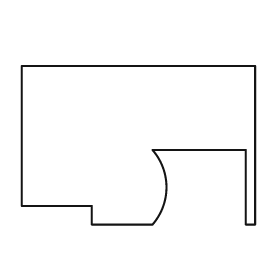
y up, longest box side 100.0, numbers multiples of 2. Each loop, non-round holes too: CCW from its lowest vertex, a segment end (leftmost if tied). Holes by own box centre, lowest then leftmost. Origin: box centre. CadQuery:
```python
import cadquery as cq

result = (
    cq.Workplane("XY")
    .moveTo(-20.0, -34.0)
    .lineTo(6.0, -34.0)
    .threePointArc((12.0, -18.0), (6.0, -2.0))
    .lineTo(46.0, -2.0)
    .lineTo(46.0, -34.0)
    .lineTo(50.0, -34.0)
    .lineTo(50.0, 34.0)
    .lineTo(-50.0, 34.0)
    .lineTo(-50.0, -26.0)
    .lineTo(-20.0, -26.0)
    .close()
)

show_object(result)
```